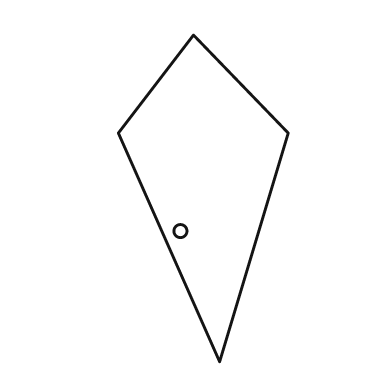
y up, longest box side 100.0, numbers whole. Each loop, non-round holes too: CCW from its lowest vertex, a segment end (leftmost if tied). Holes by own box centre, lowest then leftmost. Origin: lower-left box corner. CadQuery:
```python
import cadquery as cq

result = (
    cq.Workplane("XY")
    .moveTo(31.0, 0.0)
    .lineTo(52.0, 70.0)
    .lineTo(23.0, 100.0)
    .lineTo(0.0, 70.0)
    .close()
    .moveTo(19.0, 40.0)
    .circle(2.0)
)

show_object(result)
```